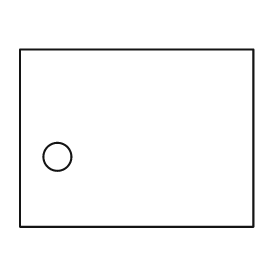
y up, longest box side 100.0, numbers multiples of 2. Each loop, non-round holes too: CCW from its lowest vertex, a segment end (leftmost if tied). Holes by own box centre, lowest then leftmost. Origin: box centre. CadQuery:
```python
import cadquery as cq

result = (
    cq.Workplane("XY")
    .moveTo(-50.0, -38.0)
    .lineTo(50.0, -38.0)
    .lineTo(50.0, 38.0)
    .lineTo(-50.0, 38.0)
    .close()
    .moveTo(-34.0, -8.0)
    .circle(6.0)
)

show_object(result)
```